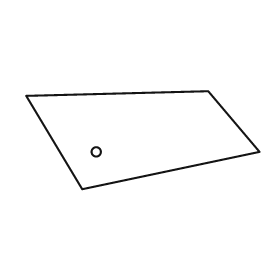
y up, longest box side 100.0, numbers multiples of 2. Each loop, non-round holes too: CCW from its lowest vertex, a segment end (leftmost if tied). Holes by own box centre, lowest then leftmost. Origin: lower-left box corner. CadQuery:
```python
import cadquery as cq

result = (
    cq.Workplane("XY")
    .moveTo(24.0, 0.0)
    .lineTo(100.0, 16.0)
    .lineTo(78.0, 42.0)
    .lineTo(0.0, 40.0)
    .close()
    .moveTo(30.0, 16.0)
    .circle(2.0)
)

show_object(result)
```